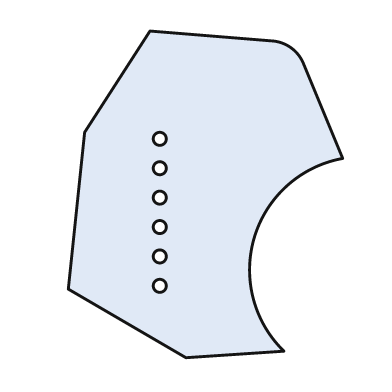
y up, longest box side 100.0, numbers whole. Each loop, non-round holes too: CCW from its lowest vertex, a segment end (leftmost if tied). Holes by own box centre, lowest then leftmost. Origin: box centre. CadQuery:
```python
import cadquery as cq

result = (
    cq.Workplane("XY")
    .moveTo(-6.0, -50.0)
    .lineTo(24.0, -48.0)
    .threePointArc((15.0, -13.0), (42.0, 11.0))
    .lineTo(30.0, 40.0)
    .threePointArc((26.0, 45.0), (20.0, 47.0))
    .lineTo(-17.0, 50.0)
    .lineTo(-37.0, 19.0)
    .lineTo(-42.0, -29.0)
    .close()
    .moveTo(-14.0, -28.0)
    .circle(2.0)
    .moveTo(-14.0, -19.0)
    .circle(2.0)
    .moveTo(-14.0, -10.0)
    .circle(2.0)
    .moveTo(-14.0, -1.0)
    .circle(2.0)
    .moveTo(-14.0, 8.0)
    .circle(2.0)
    .moveTo(-14.0, 17.0)
    .circle(2.0)
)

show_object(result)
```